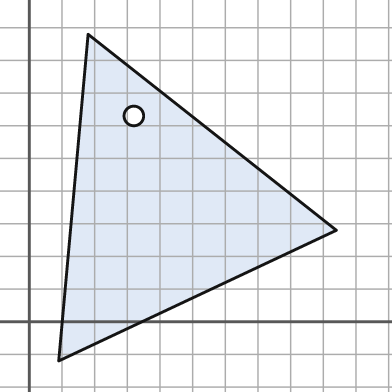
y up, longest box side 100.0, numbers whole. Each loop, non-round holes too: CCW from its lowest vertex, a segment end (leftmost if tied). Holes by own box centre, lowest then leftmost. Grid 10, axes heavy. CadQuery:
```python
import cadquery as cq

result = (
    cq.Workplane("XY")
    .moveTo(9.0, -12.0)
    .lineTo(94.0, 28.0)
    .lineTo(18.0, 88.0)
    .close()
    .moveTo(32.0, 63.0)
    .circle(3.0)
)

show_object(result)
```